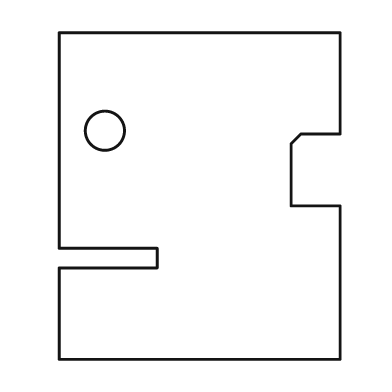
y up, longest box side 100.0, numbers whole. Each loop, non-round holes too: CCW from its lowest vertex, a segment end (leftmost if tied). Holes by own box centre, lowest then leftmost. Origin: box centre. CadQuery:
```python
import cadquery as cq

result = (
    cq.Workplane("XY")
    .moveTo(-43.0, -50.0)
    .lineTo(43.0, -50.0)
    .lineTo(43.0, -3.0)
    .lineTo(28.0, -3.0)
    .lineTo(28.0, 16.0)
    .lineTo(31.0, 19.0)
    .lineTo(43.0, 19.0)
    .lineTo(43.0, 50.0)
    .lineTo(-43.0, 50.0)
    .lineTo(-43.0, -16.0)
    .lineTo(-13.0, -16.0)
    .lineTo(-13.0, -22.0)
    .lineTo(-43.0, -22.0)
    .close()
    .moveTo(-29.0, 20.0)
    .circle(6.0)
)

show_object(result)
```